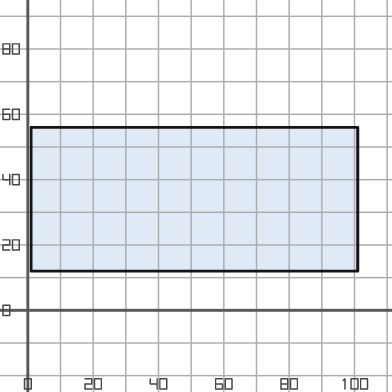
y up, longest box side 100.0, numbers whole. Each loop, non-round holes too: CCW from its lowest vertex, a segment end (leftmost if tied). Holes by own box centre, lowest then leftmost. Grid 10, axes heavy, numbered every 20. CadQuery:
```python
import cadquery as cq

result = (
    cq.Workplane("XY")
    .moveTo(1.0, 12.0)
    .lineTo(101.0, 12.0)
    .lineTo(101.0, 56.0)
    .lineTo(1.0, 56.0)
    .close()
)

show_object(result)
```